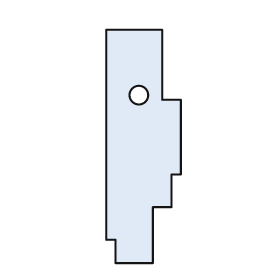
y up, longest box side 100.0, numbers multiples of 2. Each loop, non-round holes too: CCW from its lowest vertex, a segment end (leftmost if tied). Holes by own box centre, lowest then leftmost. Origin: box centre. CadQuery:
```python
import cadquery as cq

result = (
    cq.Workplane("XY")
    .moveTo(-12.0, -50.0)
    .lineTo(4.0, -50.0)
    .lineTo(4.0, -26.0)
    .lineTo(12.0, -26.0)
    .lineTo(12.0, -12.0)
    .lineTo(16.0, -12.0)
    .lineTo(16.0, 20.0)
    .lineTo(8.0, 20.0)
    .lineTo(8.0, 50.0)
    .lineTo(-16.0, 50.0)
    .lineTo(-16.0, -40.0)
    .lineTo(-12.0, -40.0)
    .close()
    .moveTo(-2.0, 22.0)
    .circle(4.0)
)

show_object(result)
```